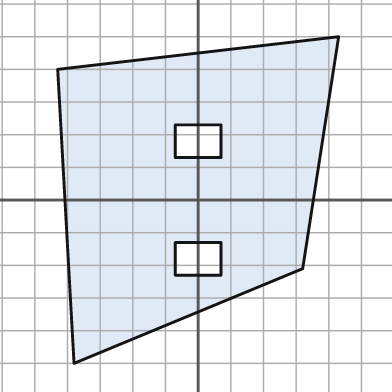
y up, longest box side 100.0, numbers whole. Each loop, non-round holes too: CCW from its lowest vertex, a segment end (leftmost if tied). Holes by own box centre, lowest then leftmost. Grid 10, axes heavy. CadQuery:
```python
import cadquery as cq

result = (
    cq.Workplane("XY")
    .moveTo(-38.0, -50.0)
    .lineTo(32.0, -21.0)
    .lineTo(43.0, 50.0)
    .lineTo(-43.0, 40.0)
    .close()
    .moveTo(-7.0, -23.0)
    .lineTo(7.0, -23.0)
    .lineTo(7.0, -13.0)
    .lineTo(-7.0, -13.0)
    .close()
    .moveTo(-7.0, 13.0)
    .lineTo(7.0, 13.0)
    .lineTo(7.0, 23.0)
    .lineTo(-7.0, 23.0)
    .close()
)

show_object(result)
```